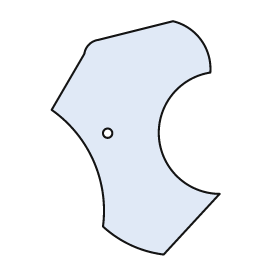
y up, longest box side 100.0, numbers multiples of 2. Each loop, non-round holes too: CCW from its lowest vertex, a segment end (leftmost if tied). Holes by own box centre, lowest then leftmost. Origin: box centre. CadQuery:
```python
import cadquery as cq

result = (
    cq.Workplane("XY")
    .moveTo(12.0, -50.0)
    .lineTo(36.0, -24.0)
    .threePointArc((10.0, 0.0), (32.0, 28.0))
    .threePointArc((28.0, 42.0), (16.0, 50.0))
    .lineTo(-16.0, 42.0)
    .threePointArc((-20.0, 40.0), (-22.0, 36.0))
    .lineTo(-36.0, 12.0)
    .threePointArc((-18.0, -10.0), (-14.0, -38.0))
    .threePointArc((-2.0, -46.0), (12.0, -50.0))
    .close()
    .moveTo(-12.0, 2.0)
    .circle(2.0)
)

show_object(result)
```